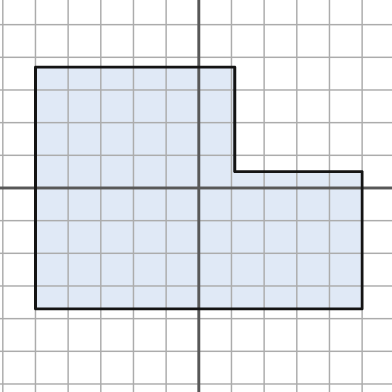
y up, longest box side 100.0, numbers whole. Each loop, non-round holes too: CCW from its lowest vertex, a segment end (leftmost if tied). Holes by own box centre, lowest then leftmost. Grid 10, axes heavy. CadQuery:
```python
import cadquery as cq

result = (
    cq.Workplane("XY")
    .moveTo(-50.0, -37.0)
    .lineTo(50.0, -37.0)
    .lineTo(50.0, 5.0)
    .lineTo(11.0, 5.0)
    .lineTo(11.0, 37.0)
    .lineTo(-50.0, 37.0)
    .close()
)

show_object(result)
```